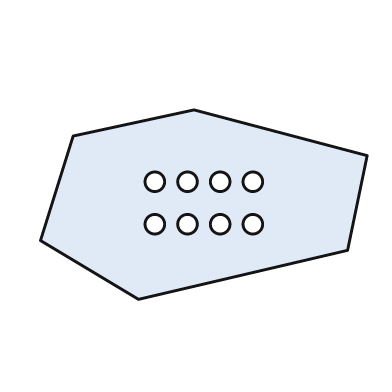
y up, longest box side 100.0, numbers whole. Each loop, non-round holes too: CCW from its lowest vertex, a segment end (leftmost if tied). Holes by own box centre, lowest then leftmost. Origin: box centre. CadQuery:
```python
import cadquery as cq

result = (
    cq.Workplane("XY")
    .moveTo(-20.0, -29.0)
    .lineTo(44.0, -14.0)
    .lineTo(50.0, 15.0)
    .lineTo(-3.0, 29.0)
    .lineTo(-40.0, 21.0)
    .lineTo(-50.0, -11.0)
    .close()
    .moveTo(-15.0, -6.0)
    .circle(3.0)
    .moveTo(-5.0, -6.0)
    .circle(3.0)
    .moveTo(5.0, -6.0)
    .circle(3.0)
    .moveTo(15.0, -6.0)
    .circle(3.0)
    .moveTo(-15.0, 7.0)
    .circle(3.0)
    .moveTo(-5.0, 7.0)
    .circle(3.0)
    .moveTo(5.0, 7.0)
    .circle(3.0)
    .moveTo(15.0, 7.0)
    .circle(3.0)
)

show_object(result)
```